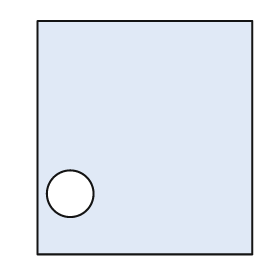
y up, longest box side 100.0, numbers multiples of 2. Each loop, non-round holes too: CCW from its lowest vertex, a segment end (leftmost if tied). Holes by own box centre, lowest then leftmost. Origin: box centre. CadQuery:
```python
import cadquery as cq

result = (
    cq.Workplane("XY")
    .moveTo(-46.0, -50.0)
    .lineTo(46.0, -50.0)
    .lineTo(46.0, 50.0)
    .lineTo(-46.0, 50.0)
    .close()
    .moveTo(-32.0, -24.0)
    .circle(10.0)
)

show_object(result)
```